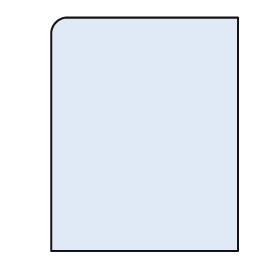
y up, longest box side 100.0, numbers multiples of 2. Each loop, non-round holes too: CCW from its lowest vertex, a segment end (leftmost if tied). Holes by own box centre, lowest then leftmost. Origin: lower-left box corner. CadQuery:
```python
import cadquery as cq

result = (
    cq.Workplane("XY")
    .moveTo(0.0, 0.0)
    .lineTo(80.0, 0.0)
    .lineTo(80.0, 100.0)
    .lineTo(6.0, 100.0)
    .threePointArc((2.0, 98.0), (0.0, 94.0))
    .close()
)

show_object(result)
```